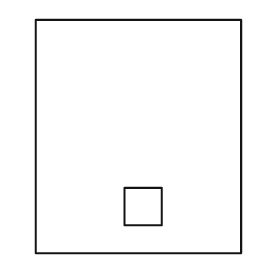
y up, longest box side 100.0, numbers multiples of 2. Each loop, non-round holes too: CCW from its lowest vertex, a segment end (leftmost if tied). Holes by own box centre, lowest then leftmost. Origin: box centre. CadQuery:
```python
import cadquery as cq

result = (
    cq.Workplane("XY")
    .moveTo(-44.0, -50.0)
    .lineTo(44.0, -50.0)
    .lineTo(44.0, 50.0)
    .lineTo(-44.0, 50.0)
    .close()
    .moveTo(-6.0, -38.0)
    .lineTo(10.0, -38.0)
    .lineTo(10.0, -22.0)
    .lineTo(-6.0, -22.0)
    .close()
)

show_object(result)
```